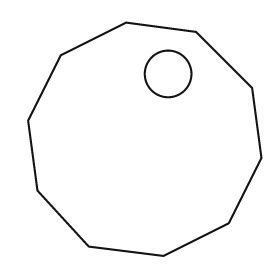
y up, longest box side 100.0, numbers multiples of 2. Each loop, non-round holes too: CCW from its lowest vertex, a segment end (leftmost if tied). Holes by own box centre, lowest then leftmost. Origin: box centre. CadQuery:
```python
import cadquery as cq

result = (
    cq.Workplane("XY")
    .moveTo(8.0, -50.0)
    .lineTo(36.0, -36.0)
    .lineTo(50.0, -8.0)
    .lineTo(46.0, 22.0)
    .lineTo(22.0, 46.0)
    .lineTo(-8.0, 50.0)
    .lineTo(-36.0, 36.0)
    .lineTo(-50.0, 8.0)
    .lineTo(-46.0, -22.0)
    .lineTo(-24.0, -46.0)
    .close()
    .moveTo(10.0, 28.0)
    .circle(10.0)
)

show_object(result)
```